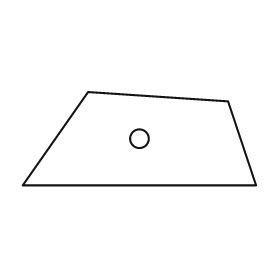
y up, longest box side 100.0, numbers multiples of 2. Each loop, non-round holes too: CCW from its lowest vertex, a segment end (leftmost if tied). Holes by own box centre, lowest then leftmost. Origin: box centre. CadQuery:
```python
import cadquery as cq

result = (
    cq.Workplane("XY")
    .moveTo(-50.0, -20.0)
    .lineTo(50.0, -20.0)
    .lineTo(38.0, 16.0)
    .lineTo(-22.0, 20.0)
    .close()
    .moveTo(0.0, 0.0)
    .circle(4.0)
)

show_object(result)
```